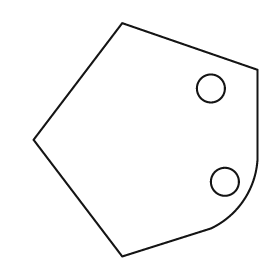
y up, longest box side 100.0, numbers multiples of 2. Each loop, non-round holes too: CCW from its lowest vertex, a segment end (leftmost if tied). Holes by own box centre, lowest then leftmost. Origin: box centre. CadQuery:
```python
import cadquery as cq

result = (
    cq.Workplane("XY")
    .moveTo(-10.0, -50.0)
    .lineTo(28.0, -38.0)
    .threePointArc((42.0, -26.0), (48.0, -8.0))
    .lineTo(48.0, 30.0)
    .lineTo(-10.0, 50.0)
    .lineTo(-48.0, 0.0)
    .close()
    .moveTo(34.0, -18.0)
    .circle(6.0)
    .moveTo(28.0, 22.0)
    .circle(6.0)
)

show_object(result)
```